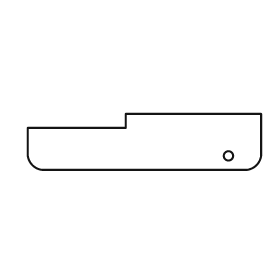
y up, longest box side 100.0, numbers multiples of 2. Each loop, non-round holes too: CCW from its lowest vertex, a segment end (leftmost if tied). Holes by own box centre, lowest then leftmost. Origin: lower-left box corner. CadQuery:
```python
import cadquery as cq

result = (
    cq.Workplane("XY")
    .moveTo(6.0, 0.0)
    .lineTo(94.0, 0.0)
    .threePointArc((98.0, 2.0), (100.0, 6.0))
    .lineTo(100.0, 24.0)
    .lineTo(42.0, 24.0)
    .lineTo(42.0, 18.0)
    .lineTo(0.0, 18.0)
    .lineTo(0.0, 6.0)
    .threePointArc((2.0, 2.0), (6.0, 0.0))
    .close()
    .moveTo(86.0, 6.0)
    .circle(2.0)
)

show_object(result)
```